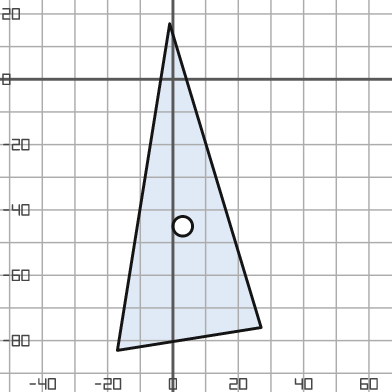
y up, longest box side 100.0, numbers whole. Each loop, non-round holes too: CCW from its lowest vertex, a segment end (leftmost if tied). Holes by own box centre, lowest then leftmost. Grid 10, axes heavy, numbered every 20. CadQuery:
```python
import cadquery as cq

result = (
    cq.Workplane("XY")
    .moveTo(-17.0, -83.0)
    .lineTo(27.0, -76.0)
    .lineTo(-1.0, 17.0)
    .close()
    .moveTo(3.0, -45.0)
    .circle(3.0)
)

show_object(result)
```